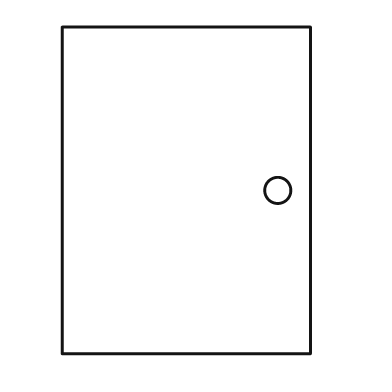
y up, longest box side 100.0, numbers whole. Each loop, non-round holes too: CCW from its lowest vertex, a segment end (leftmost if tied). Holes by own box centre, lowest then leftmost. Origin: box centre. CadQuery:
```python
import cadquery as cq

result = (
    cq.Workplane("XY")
    .moveTo(-38.0, -50.0)
    .lineTo(38.0, -50.0)
    .lineTo(38.0, 50.0)
    .lineTo(-38.0, 50.0)
    .close()
    .moveTo(28.0, 0.0)
    .circle(4.0)
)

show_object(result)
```